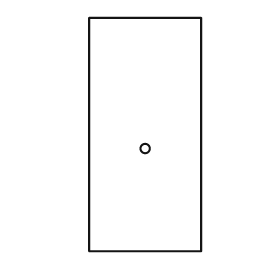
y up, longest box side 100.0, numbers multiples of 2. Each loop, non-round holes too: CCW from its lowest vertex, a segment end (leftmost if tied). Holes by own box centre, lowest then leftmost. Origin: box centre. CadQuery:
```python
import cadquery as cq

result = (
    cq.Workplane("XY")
    .moveTo(-24.0, -50.0)
    .lineTo(24.0, -50.0)
    .lineTo(24.0, 50.0)
    .lineTo(-24.0, 50.0)
    .close()
    .moveTo(0.0, -6.0)
    .circle(2.0)
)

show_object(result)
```